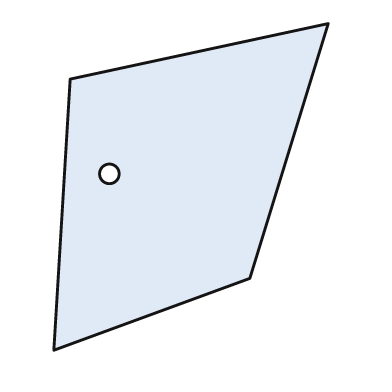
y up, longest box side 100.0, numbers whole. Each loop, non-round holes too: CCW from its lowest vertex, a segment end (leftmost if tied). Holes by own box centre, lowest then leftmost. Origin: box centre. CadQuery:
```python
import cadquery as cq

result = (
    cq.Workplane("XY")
    .moveTo(-42.0, -50.0)
    .lineTo(18.0, -28.0)
    .lineTo(42.0, 50.0)
    .lineTo(-37.0, 33.0)
    .close()
    .moveTo(-25.0, 4.0)
    .circle(3.0)
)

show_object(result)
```